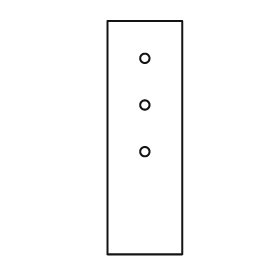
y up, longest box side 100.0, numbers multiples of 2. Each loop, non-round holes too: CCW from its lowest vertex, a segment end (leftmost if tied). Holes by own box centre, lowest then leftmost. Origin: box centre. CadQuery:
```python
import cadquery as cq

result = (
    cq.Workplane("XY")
    .moveTo(-16.0, -50.0)
    .lineTo(16.0, -50.0)
    .lineTo(16.0, 50.0)
    .lineTo(-16.0, 50.0)
    .close()
    .moveTo(0.0, -6.0)
    .circle(2.0)
    .moveTo(0.0, 14.0)
    .circle(2.0)
    .moveTo(0.0, 34.0)
    .circle(2.0)
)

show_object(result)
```